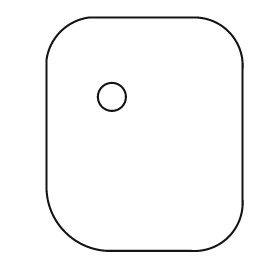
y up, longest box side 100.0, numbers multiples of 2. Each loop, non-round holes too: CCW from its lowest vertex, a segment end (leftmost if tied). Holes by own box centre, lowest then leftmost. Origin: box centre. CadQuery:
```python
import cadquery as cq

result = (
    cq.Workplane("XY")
    .moveTo(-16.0, -50.0)
    .lineTo(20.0, -50.0)
    .threePointArc((36.0, -44.0), (42.0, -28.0))
    .lineTo(42.0, 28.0)
    .threePointArc((36.0, 44.0), (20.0, 50.0))
    .lineTo(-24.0, 50.0)
    .threePointArc((-36.0, 44.0), (-42.0, 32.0))
    .lineTo(-42.0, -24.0)
    .threePointArc((-34.0, -42.0), (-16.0, -50.0))
    .close()
    .moveTo(-14.0, 16.0)
    .circle(6.0)
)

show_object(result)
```